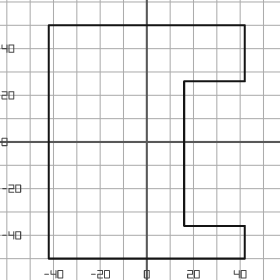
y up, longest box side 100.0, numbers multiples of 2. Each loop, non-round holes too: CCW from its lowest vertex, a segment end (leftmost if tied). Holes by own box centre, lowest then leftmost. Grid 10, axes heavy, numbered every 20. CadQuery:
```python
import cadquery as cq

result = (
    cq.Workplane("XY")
    .moveTo(-42.0, -50.0)
    .lineTo(42.0, -50.0)
    .lineTo(42.0, -36.0)
    .lineTo(16.0, -36.0)
    .lineTo(16.0, 26.0)
    .lineTo(42.0, 26.0)
    .lineTo(42.0, 50.0)
    .lineTo(-42.0, 50.0)
    .close()
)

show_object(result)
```